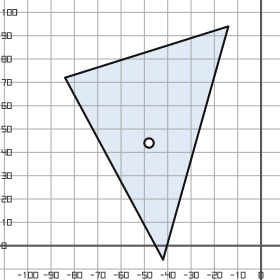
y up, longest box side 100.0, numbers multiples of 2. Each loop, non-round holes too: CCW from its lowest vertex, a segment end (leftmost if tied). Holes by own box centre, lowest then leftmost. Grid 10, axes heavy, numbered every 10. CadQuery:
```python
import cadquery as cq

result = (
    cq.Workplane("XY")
    .moveTo(-42.0, -6.0)
    .lineTo(-14.0, 94.0)
    .lineTo(-84.0, 72.0)
    .close()
    .moveTo(-48.0, 44.0)
    .circle(2.0)
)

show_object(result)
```